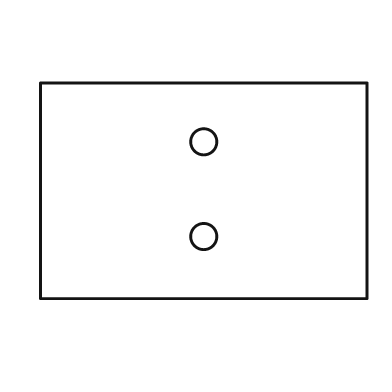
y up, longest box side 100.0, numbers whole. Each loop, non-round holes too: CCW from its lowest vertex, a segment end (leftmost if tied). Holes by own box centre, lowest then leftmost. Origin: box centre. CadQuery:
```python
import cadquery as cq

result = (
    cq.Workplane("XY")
    .moveTo(-50.0, -33.0)
    .lineTo(50.0, -33.0)
    .lineTo(50.0, 33.0)
    .lineTo(-50.0, 33.0)
    .close()
    .moveTo(0.0, -14.0)
    .circle(4.0)
    .moveTo(0.0, 15.0)
    .circle(4.0)
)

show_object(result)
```